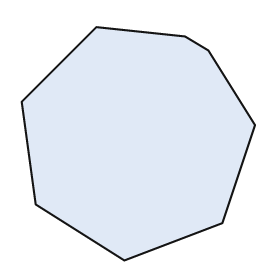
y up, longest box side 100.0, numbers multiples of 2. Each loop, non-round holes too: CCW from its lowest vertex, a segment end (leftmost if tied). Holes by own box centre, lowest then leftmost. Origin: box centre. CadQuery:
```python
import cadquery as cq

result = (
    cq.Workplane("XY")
    .moveTo(-6.0, -50.0)
    .lineTo(36.0, -34.0)
    .lineTo(50.0, 8.0)
    .lineTo(30.0, 40.0)
    .lineTo(20.0, 46.0)
    .lineTo(-18.0, 50.0)
    .lineTo(-50.0, 18.0)
    .lineTo(-44.0, -26.0)
    .close()
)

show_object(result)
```